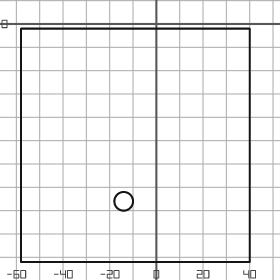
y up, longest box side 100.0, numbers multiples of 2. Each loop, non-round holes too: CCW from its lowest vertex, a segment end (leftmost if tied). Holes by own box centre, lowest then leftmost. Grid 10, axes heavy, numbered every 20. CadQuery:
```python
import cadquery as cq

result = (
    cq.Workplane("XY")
    .moveTo(-58.0, -102.0)
    .lineTo(40.0, -102.0)
    .lineTo(40.0, -2.0)
    .lineTo(-58.0, -2.0)
    .close()
    .moveTo(-14.0, -76.0)
    .circle(4.0)
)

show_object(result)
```